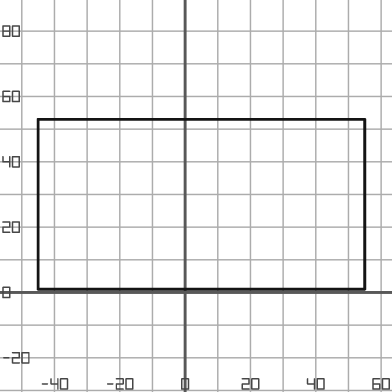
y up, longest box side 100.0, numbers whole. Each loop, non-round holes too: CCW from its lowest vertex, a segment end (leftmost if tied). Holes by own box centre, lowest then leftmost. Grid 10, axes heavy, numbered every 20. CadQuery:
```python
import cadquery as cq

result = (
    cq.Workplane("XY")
    .moveTo(-45.0, 1.0)
    .lineTo(55.0, 1.0)
    .lineTo(55.0, 53.0)
    .lineTo(-45.0, 53.0)
    .close()
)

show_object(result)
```